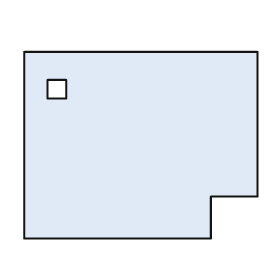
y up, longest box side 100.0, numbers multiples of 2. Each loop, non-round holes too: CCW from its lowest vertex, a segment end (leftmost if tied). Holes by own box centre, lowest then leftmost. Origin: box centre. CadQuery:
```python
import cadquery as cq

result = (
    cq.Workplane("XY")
    .moveTo(-50.0, -40.0)
    .lineTo(30.0, -40.0)
    .lineTo(30.0, -22.0)
    .lineTo(50.0, -22.0)
    .lineTo(50.0, 40.0)
    .lineTo(-50.0, 40.0)
    .close()
    .moveTo(-40.0, 20.0)
    .lineTo(-32.0, 20.0)
    .lineTo(-32.0, 28.0)
    .lineTo(-40.0, 28.0)
    .close()
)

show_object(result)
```